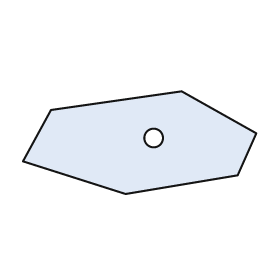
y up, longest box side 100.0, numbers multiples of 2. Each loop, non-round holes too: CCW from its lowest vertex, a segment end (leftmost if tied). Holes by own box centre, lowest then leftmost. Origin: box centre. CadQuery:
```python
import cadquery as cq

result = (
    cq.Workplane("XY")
    .moveTo(-6.0, -22.0)
    .lineTo(42.0, -14.0)
    .lineTo(50.0, 4.0)
    .lineTo(18.0, 22.0)
    .lineTo(-38.0, 14.0)
    .lineTo(-50.0, -8.0)
    .close()
    .moveTo(6.0, 2.0)
    .circle(4.0)
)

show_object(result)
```